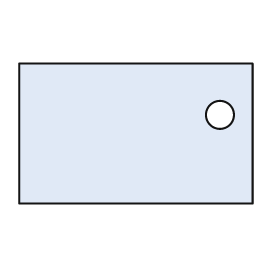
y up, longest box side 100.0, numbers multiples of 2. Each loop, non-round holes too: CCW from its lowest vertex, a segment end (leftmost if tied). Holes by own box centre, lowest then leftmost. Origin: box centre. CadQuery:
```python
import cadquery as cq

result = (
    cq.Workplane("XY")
    .moveTo(-50.0, -30.0)
    .lineTo(50.0, -30.0)
    .lineTo(50.0, 30.0)
    .lineTo(-50.0, 30.0)
    .close()
    .moveTo(36.0, 8.0)
    .circle(6.0)
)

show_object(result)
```